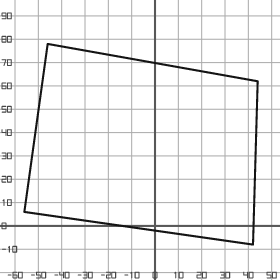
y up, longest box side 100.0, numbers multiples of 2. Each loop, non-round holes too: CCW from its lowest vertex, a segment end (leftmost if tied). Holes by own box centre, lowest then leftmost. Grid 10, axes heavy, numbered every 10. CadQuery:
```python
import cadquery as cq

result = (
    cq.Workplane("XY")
    .moveTo(42.0, -8.0)
    .lineTo(44.0, 62.0)
    .lineTo(-46.0, 78.0)
    .lineTo(-56.0, 6.0)
    .close()
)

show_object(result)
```